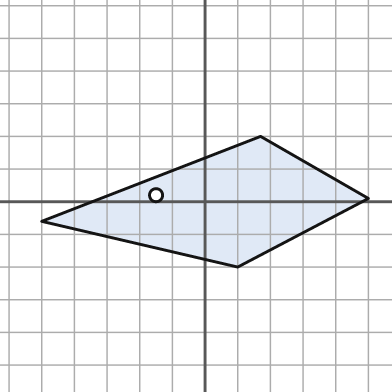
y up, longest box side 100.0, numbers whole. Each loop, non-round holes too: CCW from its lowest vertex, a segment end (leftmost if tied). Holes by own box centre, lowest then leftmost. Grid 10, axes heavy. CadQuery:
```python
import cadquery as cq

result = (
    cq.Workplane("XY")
    .moveTo(10.0, -20.0)
    .lineTo(50.0, 1.0)
    .lineTo(17.0, 20.0)
    .lineTo(-50.0, -6.0)
    .close()
    .moveTo(-15.0, 2.0)
    .circle(2.0)
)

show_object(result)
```